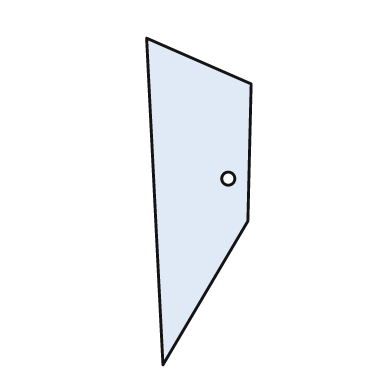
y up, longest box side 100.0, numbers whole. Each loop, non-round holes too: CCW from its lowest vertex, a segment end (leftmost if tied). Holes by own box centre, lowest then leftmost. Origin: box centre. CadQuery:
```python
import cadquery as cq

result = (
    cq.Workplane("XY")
    .moveTo(-11.0, -50.0)
    .lineTo(15.0, -6.0)
    .lineTo(16.0, 36.0)
    .lineTo(-16.0, 50.0)
    .close()
    .moveTo(9.0, 7.0)
    .circle(2.0)
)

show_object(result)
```